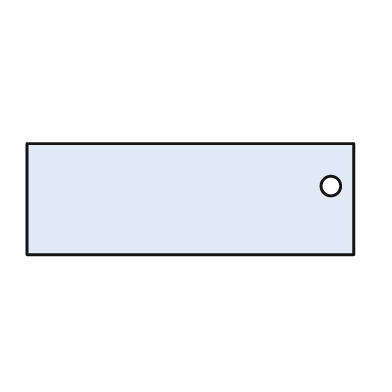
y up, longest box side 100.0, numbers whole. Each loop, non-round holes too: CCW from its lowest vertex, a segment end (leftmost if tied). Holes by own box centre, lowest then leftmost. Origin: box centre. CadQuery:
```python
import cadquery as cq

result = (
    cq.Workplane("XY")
    .moveTo(-50.0, -17.0)
    .lineTo(50.0, -17.0)
    .lineTo(50.0, 17.0)
    .lineTo(-50.0, 17.0)
    .close()
    .moveTo(43.0, 4.0)
    .circle(3.0)
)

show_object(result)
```